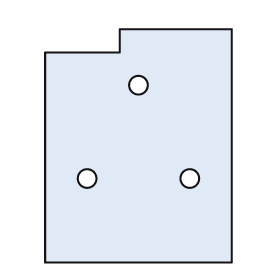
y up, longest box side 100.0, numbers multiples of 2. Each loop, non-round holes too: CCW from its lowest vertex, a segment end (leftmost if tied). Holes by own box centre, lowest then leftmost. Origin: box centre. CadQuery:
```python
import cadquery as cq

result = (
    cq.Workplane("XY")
    .moveTo(-40.0, -50.0)
    .lineTo(40.0, -50.0)
    .lineTo(40.0, 50.0)
    .lineTo(-8.0, 50.0)
    .lineTo(-8.0, 40.0)
    .lineTo(-40.0, 40.0)
    .close()
    .moveTo(-22.0, -14.0)
    .circle(4.0)
    .moveTo(22.0, -14.0)
    .circle(4.0)
    .moveTo(0.0, 26.0)
    .circle(4.0)
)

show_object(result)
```